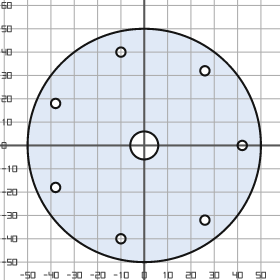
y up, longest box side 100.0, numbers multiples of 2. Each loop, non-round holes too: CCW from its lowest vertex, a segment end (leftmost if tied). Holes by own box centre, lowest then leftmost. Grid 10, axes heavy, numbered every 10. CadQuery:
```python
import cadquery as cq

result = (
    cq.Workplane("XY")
    .moveTo(0.0, 0.0)
    .circle(50.0)
    .moveTo(-10.0, -40.0)
    .circle(2.0)
    .moveTo(26.0, -32.0)
    .circle(2.0)
    .moveTo(-38.0, -18.0)
    .circle(2.0)
    .moveTo(0.0, 0.0)
    .circle(6.0)
    .moveTo(42.0, 0.0)
    .circle(2.0)
    .moveTo(-38.0, 18.0)
    .circle(2.0)
    .moveTo(26.0, 32.0)
    .circle(2.0)
    .moveTo(-10.0, 40.0)
    .circle(2.0)
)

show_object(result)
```